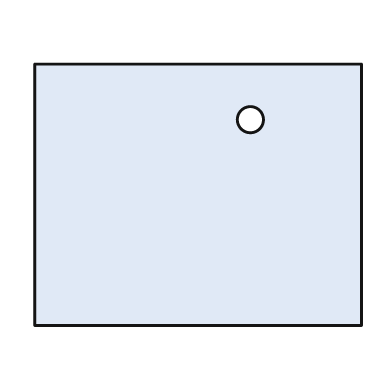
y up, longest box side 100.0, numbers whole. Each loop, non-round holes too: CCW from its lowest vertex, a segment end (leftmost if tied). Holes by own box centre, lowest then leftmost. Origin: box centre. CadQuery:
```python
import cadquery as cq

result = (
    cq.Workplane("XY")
    .moveTo(-50.0, -40.0)
    .lineTo(50.0, -40.0)
    .lineTo(50.0, 40.0)
    .lineTo(-50.0, 40.0)
    .close()
    .moveTo(16.0, 23.0)
    .circle(4.0)
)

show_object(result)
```